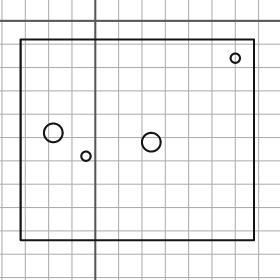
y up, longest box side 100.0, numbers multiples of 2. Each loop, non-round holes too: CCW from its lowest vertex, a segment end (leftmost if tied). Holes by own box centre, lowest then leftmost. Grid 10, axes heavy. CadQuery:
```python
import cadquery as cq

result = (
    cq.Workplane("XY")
    .moveTo(-32.0, -94.0)
    .lineTo(68.0, -94.0)
    .lineTo(68.0, -8.0)
    .lineTo(-32.0, -8.0)
    .close()
    .moveTo(-4.0, -58.0)
    .circle(2.0)
    .moveTo(24.0, -52.0)
    .circle(4.0)
    .moveTo(-18.0, -48.0)
    .circle(4.0)
    .moveTo(60.0, -16.0)
    .circle(2.0)
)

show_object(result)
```